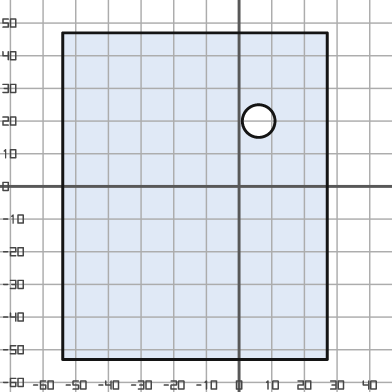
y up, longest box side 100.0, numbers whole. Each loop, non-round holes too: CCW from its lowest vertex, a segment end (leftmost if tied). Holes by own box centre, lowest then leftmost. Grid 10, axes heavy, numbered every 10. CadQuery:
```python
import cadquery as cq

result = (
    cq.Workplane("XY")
    .moveTo(-54.0, -53.0)
    .lineTo(27.0, -53.0)
    .lineTo(27.0, 47.0)
    .lineTo(-54.0, 47.0)
    .close()
    .moveTo(6.0, 20.0)
    .circle(5.0)
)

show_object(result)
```